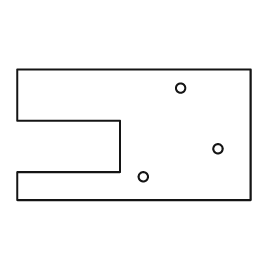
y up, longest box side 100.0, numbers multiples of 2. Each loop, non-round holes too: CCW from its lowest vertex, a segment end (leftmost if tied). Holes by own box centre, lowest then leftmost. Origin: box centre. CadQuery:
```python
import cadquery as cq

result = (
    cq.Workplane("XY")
    .moveTo(-50.0, -28.0)
    .lineTo(50.0, -28.0)
    .lineTo(50.0, 28.0)
    .lineTo(-50.0, 28.0)
    .lineTo(-50.0, 6.0)
    .lineTo(-6.0, 6.0)
    .lineTo(-6.0, -16.0)
    .lineTo(-50.0, -16.0)
    .close()
    .moveTo(4.0, -18.0)
    .circle(2.0)
    .moveTo(36.0, -6.0)
    .circle(2.0)
    .moveTo(20.0, 20.0)
    .circle(2.0)
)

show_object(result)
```